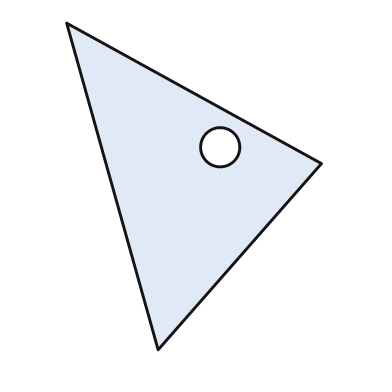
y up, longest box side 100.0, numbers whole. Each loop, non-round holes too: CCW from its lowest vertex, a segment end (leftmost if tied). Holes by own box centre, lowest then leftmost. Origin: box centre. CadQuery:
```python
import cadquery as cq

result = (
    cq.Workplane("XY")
    .moveTo(-11.0, -50.0)
    .lineTo(39.0, 7.0)
    .lineTo(-39.0, 50.0)
    .close()
    .moveTo(8.0, 12.0)
    .circle(6.0)
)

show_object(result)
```